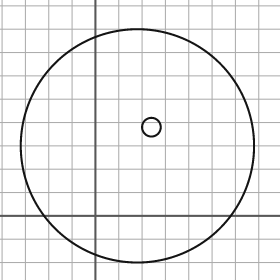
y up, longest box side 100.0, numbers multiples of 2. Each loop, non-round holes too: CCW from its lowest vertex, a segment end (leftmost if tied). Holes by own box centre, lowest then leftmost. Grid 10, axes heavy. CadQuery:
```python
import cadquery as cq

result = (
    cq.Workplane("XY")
    .moveTo(18.0, 30.0)
    .circle(50.0)
    .moveTo(24.0, 38.0)
    .circle(4.0)
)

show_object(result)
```